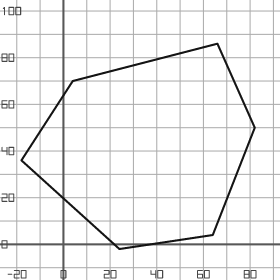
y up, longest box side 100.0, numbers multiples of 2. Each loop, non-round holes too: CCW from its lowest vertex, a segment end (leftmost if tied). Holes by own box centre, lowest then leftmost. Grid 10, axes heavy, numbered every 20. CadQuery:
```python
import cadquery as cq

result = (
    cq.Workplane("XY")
    .moveTo(24.0, -2.0)
    .lineTo(64.0, 4.0)
    .lineTo(82.0, 50.0)
    .lineTo(66.0, 86.0)
    .lineTo(4.0, 70.0)
    .lineTo(-18.0, 36.0)
    .close()
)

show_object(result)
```